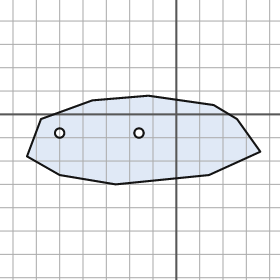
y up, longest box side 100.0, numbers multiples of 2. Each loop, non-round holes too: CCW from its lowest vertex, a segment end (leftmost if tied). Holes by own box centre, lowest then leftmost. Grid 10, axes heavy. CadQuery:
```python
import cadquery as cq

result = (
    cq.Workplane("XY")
    .moveTo(-26.0, -30.0)
    .lineTo(14.0, -26.0)
    .lineTo(36.0, -16.0)
    .lineTo(26.0, -2.0)
    .lineTo(16.0, 4.0)
    .lineTo(-12.0, 8.0)
    .lineTo(-36.0, 6.0)
    .lineTo(-58.0, -2.0)
    .lineTo(-64.0, -18.0)
    .lineTo(-50.0, -26.0)
    .close()
    .moveTo(-50.0, -8.0)
    .circle(2.0)
    .moveTo(-16.0, -8.0)
    .circle(2.0)
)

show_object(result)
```